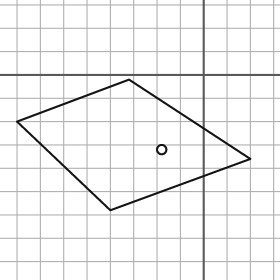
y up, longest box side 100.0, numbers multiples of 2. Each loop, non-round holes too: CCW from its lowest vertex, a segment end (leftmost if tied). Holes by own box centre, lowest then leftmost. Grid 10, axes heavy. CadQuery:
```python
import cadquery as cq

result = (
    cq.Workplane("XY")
    .moveTo(-40.0, -58.0)
    .lineTo(20.0, -36.0)
    .lineTo(-32.0, -2.0)
    .lineTo(-80.0, -20.0)
    .close()
    .moveTo(-18.0, -32.0)
    .circle(2.0)
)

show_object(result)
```